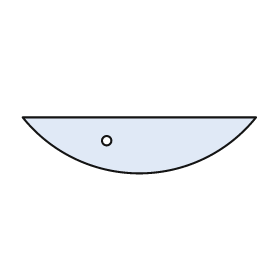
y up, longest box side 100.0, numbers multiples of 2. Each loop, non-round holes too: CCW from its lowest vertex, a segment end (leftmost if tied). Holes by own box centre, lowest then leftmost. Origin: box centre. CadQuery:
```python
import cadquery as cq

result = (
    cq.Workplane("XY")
    .moveTo(-50.0, 12.0)
    .threePointArc((0.0, -12.0), (50.0, 12.0))
    .close()
    .moveTo(-14.0, 2.0)
    .circle(2.0)
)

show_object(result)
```